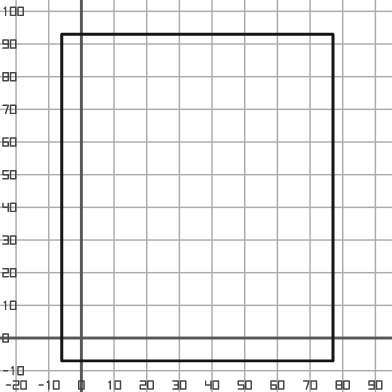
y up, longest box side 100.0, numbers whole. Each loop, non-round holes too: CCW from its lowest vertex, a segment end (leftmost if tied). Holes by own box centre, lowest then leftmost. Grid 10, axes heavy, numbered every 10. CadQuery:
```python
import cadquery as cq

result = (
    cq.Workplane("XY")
    .moveTo(-6.0, -7.0)
    .lineTo(77.0, -7.0)
    .lineTo(77.0, 93.0)
    .lineTo(-6.0, 93.0)
    .close()
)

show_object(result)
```